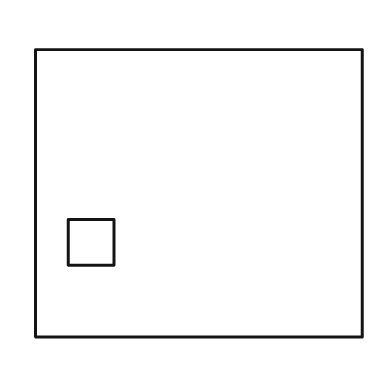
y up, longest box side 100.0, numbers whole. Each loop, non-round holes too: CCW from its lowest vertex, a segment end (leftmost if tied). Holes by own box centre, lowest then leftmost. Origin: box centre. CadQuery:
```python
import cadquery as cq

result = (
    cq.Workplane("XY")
    .moveTo(-50.0, -44.0)
    .lineTo(50.0, -44.0)
    .lineTo(50.0, 44.0)
    .lineTo(-50.0, 44.0)
    .close()
    .moveTo(-40.0, -22.0)
    .lineTo(-26.0, -22.0)
    .lineTo(-26.0, -8.0)
    .lineTo(-40.0, -8.0)
    .close()
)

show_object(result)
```